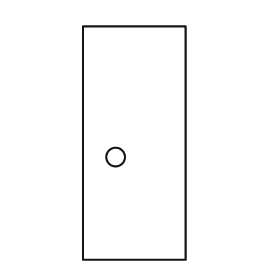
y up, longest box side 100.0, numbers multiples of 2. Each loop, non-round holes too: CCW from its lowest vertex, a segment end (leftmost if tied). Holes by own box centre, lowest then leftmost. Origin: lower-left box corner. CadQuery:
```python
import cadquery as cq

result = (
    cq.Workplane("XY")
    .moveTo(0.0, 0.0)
    .lineTo(44.0, 0.0)
    .lineTo(44.0, 100.0)
    .lineTo(0.0, 100.0)
    .close()
    .moveTo(14.0, 44.0)
    .circle(4.0)
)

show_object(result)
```